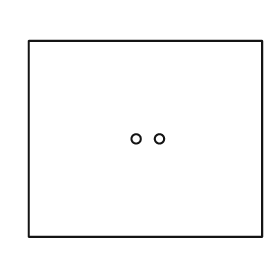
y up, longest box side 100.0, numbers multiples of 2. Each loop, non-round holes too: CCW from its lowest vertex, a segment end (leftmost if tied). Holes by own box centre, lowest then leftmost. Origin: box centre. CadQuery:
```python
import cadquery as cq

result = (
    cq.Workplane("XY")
    .moveTo(-50.0, -42.0)
    .lineTo(50.0, -42.0)
    .lineTo(50.0, 42.0)
    .lineTo(-50.0, 42.0)
    .close()
    .moveTo(-4.0, 0.0)
    .circle(2.0)
    .moveTo(6.0, 0.0)
    .circle(2.0)
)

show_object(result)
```